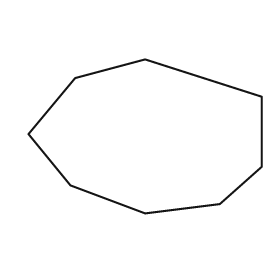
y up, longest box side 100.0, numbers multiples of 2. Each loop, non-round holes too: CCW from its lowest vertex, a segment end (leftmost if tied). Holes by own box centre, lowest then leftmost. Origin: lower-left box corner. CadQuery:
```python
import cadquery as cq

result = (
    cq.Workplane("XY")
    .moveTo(50.0, 0.0)
    .lineTo(82.0, 4.0)
    .lineTo(100.0, 20.0)
    .lineTo(100.0, 50.0)
    .lineTo(50.0, 66.0)
    .lineTo(20.0, 58.0)
    .lineTo(0.0, 34.0)
    .lineTo(18.0, 12.0)
    .close()
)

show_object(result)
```